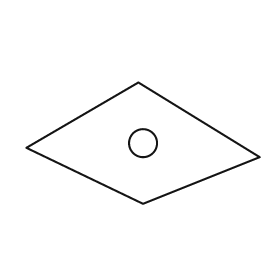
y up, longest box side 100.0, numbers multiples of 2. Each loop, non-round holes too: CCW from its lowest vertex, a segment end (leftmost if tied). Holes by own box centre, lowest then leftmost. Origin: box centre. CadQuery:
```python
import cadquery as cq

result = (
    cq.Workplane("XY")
    .moveTo(0.0, -26.0)
    .lineTo(50.0, -6.0)
    .lineTo(-2.0, 26.0)
    .lineTo(-50.0, -2.0)
    .close()
    .moveTo(0.0, 0.0)
    .circle(6.0)
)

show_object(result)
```